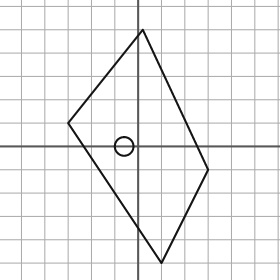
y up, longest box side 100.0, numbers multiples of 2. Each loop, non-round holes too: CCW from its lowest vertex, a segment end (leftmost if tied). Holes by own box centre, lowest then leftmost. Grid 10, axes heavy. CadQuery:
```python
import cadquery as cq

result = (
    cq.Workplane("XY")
    .moveTo(10.0, -50.0)
    .lineTo(30.0, -10.0)
    .lineTo(2.0, 50.0)
    .lineTo(-30.0, 10.0)
    .close()
    .moveTo(-6.0, 0.0)
    .circle(4.0)
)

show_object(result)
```